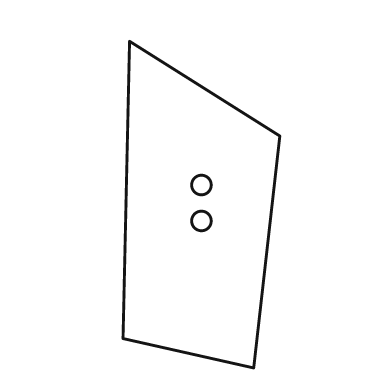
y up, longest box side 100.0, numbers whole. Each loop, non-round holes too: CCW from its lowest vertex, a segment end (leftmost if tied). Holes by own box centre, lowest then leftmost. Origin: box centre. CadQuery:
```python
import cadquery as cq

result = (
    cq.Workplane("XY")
    .moveTo(16.0, -50.0)
    .lineTo(24.0, 21.0)
    .lineTo(-22.0, 50.0)
    .lineTo(-24.0, -41.0)
    .close()
    .moveTo(0.0, -5.0)
    .circle(3.0)
    .moveTo(0.0, 6.0)
    .circle(3.0)
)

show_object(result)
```